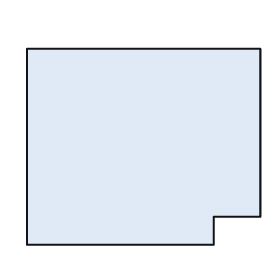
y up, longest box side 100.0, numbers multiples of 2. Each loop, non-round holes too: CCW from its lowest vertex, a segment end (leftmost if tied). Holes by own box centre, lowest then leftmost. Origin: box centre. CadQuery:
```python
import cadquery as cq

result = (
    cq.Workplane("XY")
    .moveTo(-50.0, -42.0)
    .lineTo(30.0, -42.0)
    .lineTo(30.0, -30.0)
    .lineTo(50.0, -30.0)
    .lineTo(50.0, 42.0)
    .lineTo(-50.0, 42.0)
    .close()
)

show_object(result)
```